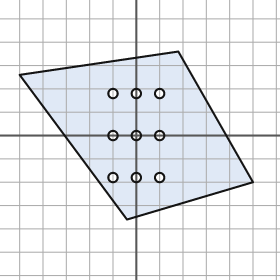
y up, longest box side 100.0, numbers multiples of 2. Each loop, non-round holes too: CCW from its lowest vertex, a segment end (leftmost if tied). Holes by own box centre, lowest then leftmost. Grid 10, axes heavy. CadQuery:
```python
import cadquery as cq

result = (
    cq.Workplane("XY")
    .moveTo(-4.0, -36.0)
    .lineTo(50.0, -20.0)
    .lineTo(18.0, 36.0)
    .lineTo(-50.0, 26.0)
    .close()
    .moveTo(-10.0, -18.0)
    .circle(2.0)
    .moveTo(0.0, -18.0)
    .circle(2.0)
    .moveTo(10.0, -18.0)
    .circle(2.0)
    .moveTo(-10.0, 0.0)
    .circle(2.0)
    .moveTo(0.0, 0.0)
    .circle(2.0)
    .moveTo(10.0, 0.0)
    .circle(2.0)
    .moveTo(-10.0, 18.0)
    .circle(2.0)
    .moveTo(0.0, 18.0)
    .circle(2.0)
    .moveTo(10.0, 18.0)
    .circle(2.0)
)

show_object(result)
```